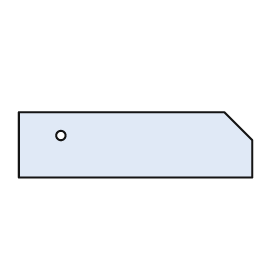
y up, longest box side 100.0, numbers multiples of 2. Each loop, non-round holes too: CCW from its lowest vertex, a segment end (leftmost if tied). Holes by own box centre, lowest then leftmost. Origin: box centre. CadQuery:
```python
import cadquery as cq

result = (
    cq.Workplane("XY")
    .moveTo(-50.0, -14.0)
    .lineTo(50.0, -14.0)
    .lineTo(50.0, 2.0)
    .lineTo(38.0, 14.0)
    .lineTo(-50.0, 14.0)
    .close()
    .moveTo(-32.0, 4.0)
    .circle(2.0)
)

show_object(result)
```